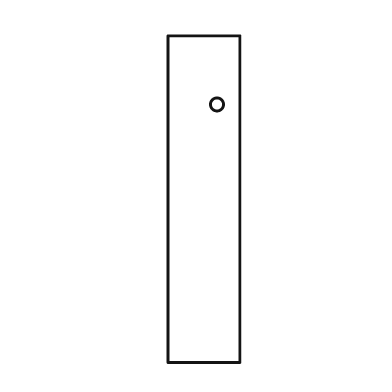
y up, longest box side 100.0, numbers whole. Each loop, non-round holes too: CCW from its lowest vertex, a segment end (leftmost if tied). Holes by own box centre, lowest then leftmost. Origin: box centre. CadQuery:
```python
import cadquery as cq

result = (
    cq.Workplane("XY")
    .moveTo(-11.0, -50.0)
    .lineTo(11.0, -50.0)
    .lineTo(11.0, 50.0)
    .lineTo(-11.0, 50.0)
    .close()
    .moveTo(4.0, 29.0)
    .circle(2.0)
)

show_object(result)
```